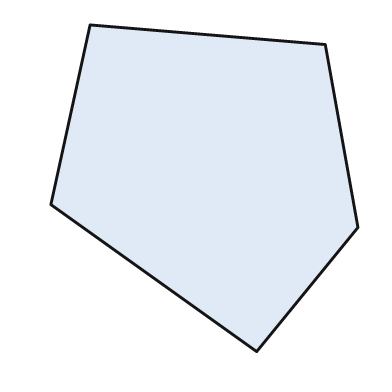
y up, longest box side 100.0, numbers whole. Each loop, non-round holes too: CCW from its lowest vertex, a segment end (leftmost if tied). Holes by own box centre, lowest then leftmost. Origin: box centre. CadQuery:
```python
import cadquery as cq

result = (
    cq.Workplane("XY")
    .moveTo(16.0, -50.0)
    .lineTo(47.0, -12.0)
    .lineTo(37.0, 44.0)
    .lineTo(-35.0, 50.0)
    .lineTo(-47.0, -5.0)
    .close()
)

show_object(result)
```